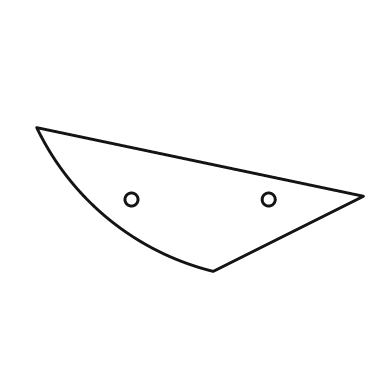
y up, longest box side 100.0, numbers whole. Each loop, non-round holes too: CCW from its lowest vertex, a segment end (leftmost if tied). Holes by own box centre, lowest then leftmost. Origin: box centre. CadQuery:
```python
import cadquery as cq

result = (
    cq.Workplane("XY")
    .moveTo(4.0, -22.0)
    .lineTo(50.0, 1.0)
    .lineTo(-50.0, 22.0)
    .threePointArc((-28.0, -6.0), (4.0, -22.0))
    .close()
    .moveTo(-21.0, 0.0)
    .circle(2.0)
    .moveTo(21.0, 0.0)
    .circle(2.0)
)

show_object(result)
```